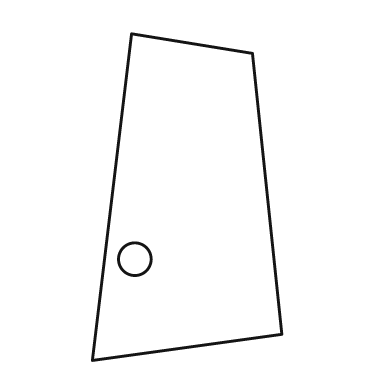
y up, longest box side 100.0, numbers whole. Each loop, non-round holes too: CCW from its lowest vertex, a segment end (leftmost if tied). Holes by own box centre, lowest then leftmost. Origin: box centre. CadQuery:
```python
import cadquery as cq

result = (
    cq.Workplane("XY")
    .moveTo(-29.0, -50.0)
    .lineTo(29.0, -42.0)
    .lineTo(20.0, 44.0)
    .lineTo(-17.0, 50.0)
    .close()
    .moveTo(-16.0, -19.0)
    .circle(5.0)
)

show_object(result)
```